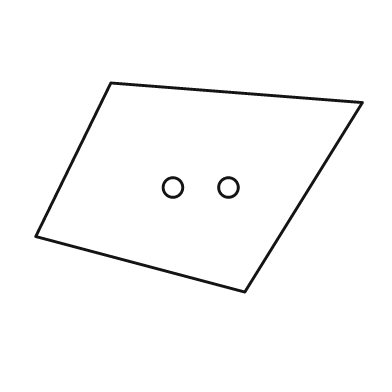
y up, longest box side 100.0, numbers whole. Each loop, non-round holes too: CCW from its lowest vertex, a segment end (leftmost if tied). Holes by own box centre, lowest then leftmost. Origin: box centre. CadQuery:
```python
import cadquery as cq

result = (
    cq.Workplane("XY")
    .moveTo(14.0, -32.0)
    .lineTo(50.0, 26.0)
    .lineTo(-27.0, 32.0)
    .lineTo(-50.0, -15.0)
    .close()
    .moveTo(-8.0, 0.0)
    .circle(3.0)
    .moveTo(9.0, 0.0)
    .circle(3.0)
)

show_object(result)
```